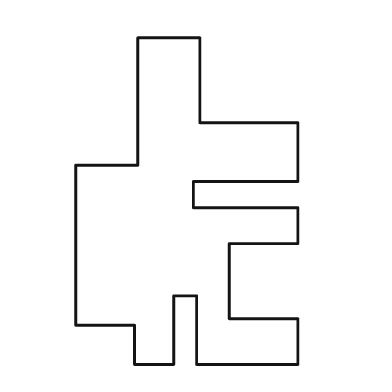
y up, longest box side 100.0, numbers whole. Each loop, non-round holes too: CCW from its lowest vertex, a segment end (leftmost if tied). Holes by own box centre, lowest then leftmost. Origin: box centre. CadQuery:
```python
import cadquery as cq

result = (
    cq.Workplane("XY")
    .moveTo(-16.0, -50.0)
    .lineTo(-4.0, -50.0)
    .lineTo(-4.0, -29.0)
    .lineTo(3.0, -29.0)
    .lineTo(3.0, -50.0)
    .lineTo(34.0, -50.0)
    .lineTo(34.0, -36.0)
    .lineTo(13.0, -36.0)
    .lineTo(13.0, -13.0)
    .lineTo(34.0, -13.0)
    .lineTo(34.0, -2.0)
    .lineTo(2.0, -2.0)
    .lineTo(2.0, 6.0)
    .lineTo(34.0, 6.0)
    .lineTo(34.0, 24.0)
    .lineTo(4.0, 24.0)
    .lineTo(4.0, 50.0)
    .lineTo(-15.0, 50.0)
    .lineTo(-15.0, 11.0)
    .lineTo(-34.0, 11.0)
    .lineTo(-34.0, -38.0)
    .lineTo(-16.0, -38.0)
    .close()
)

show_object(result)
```